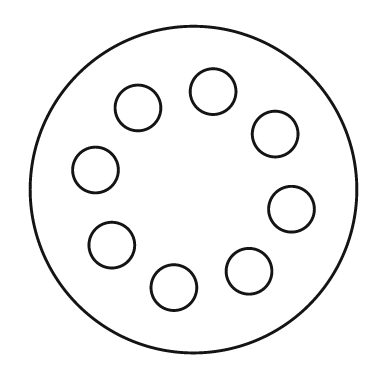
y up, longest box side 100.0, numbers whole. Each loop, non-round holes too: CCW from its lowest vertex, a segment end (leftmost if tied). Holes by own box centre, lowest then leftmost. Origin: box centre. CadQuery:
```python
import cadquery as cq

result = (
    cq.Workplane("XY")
    .moveTo(0.0, 0.0)
    .circle(50.0)
    .moveTo(-6.0, -30.0)
    .circle(7.0)
    .moveTo(17.0, -25.0)
    .circle(7.0)
    .moveTo(-25.0, -17.0)
    .circle(7.0)
    .moveTo(30.0, -6.0)
    .circle(7.0)
    .moveTo(-30.0, 6.0)
    .circle(7.0)
    .moveTo(25.0, 17.0)
    .circle(7.0)
    .moveTo(-17.0, 25.0)
    .circle(7.0)
    .moveTo(6.0, 30.0)
    .circle(7.0)
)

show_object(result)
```